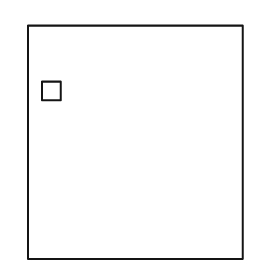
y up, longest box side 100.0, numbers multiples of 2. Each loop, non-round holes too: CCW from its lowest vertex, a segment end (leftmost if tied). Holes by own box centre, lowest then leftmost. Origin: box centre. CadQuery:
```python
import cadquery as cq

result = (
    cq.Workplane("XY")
    .moveTo(-46.0, -50.0)
    .lineTo(46.0, -50.0)
    .lineTo(46.0, 50.0)
    .lineTo(-46.0, 50.0)
    .close()
    .moveTo(-40.0, 18.0)
    .lineTo(-32.0, 18.0)
    .lineTo(-32.0, 26.0)
    .lineTo(-40.0, 26.0)
    .close()
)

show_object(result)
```